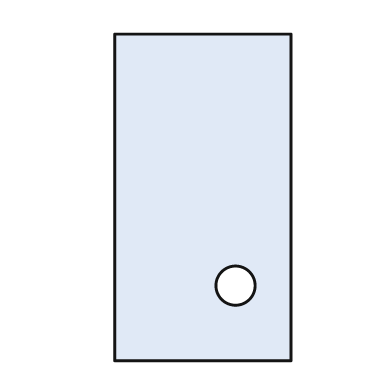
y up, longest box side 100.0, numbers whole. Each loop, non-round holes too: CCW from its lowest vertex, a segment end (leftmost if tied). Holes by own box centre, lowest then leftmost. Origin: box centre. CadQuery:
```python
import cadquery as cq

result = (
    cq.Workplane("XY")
    .moveTo(-27.0, -50.0)
    .lineTo(27.0, -50.0)
    .lineTo(27.0, 50.0)
    .lineTo(-27.0, 50.0)
    .close()
    .moveTo(10.0, -27.0)
    .circle(6.0)
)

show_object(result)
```